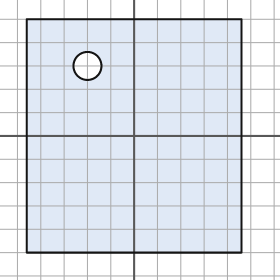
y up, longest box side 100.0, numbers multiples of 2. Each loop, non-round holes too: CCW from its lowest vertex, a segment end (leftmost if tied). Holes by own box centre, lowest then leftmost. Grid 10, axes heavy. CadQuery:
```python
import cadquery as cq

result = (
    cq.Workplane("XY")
    .moveTo(-46.0, -50.0)
    .lineTo(46.0, -50.0)
    .lineTo(46.0, 50.0)
    .lineTo(-46.0, 50.0)
    .close()
    .moveTo(-20.0, 30.0)
    .circle(6.0)
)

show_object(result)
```